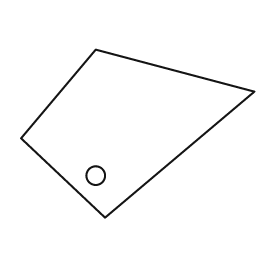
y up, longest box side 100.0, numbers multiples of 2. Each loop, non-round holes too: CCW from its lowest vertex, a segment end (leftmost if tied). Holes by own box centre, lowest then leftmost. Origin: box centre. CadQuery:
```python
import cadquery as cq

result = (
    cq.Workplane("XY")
    .moveTo(-14.0, -36.0)
    .lineTo(50.0, 18.0)
    .lineTo(-18.0, 36.0)
    .lineTo(-50.0, -2.0)
    .close()
    .moveTo(-18.0, -18.0)
    .circle(4.0)
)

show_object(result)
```